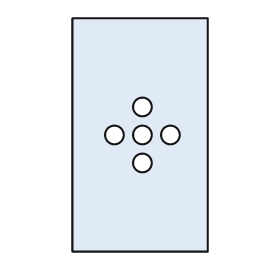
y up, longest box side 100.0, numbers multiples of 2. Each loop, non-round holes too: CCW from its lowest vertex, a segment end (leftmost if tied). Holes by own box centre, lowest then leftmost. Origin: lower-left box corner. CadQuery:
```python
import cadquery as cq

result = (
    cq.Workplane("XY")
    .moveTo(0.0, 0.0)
    .lineTo(58.0, 0.0)
    .lineTo(58.0, 100.0)
    .lineTo(0.0, 100.0)
    .close()
    .moveTo(30.0, 38.0)
    .circle(4.0)
    .moveTo(18.0, 50.0)
    .circle(4.0)
    .moveTo(30.0, 50.0)
    .circle(4.0)
    .moveTo(42.0, 50.0)
    .circle(4.0)
    .moveTo(30.0, 62.0)
    .circle(4.0)
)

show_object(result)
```